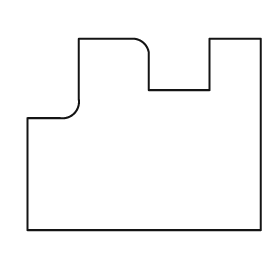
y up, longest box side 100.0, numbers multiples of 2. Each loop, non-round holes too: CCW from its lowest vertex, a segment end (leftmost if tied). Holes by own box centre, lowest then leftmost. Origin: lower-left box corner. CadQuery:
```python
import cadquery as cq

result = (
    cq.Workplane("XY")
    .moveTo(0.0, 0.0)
    .lineTo(100.0, 0.0)
    .lineTo(100.0, 82.0)
    .lineTo(78.0, 82.0)
    .lineTo(78.0, 60.0)
    .lineTo(52.0, 60.0)
    .lineTo(52.0, 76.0)
    .threePointArc((50.0, 80.0), (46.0, 82.0))
    .lineTo(22.0, 82.0)
    .lineTo(22.0, 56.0)
    .threePointArc((20.0, 50.0), (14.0, 48.0))
    .lineTo(0.0, 48.0)
    .close()
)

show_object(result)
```